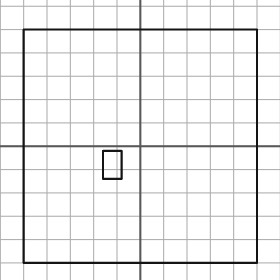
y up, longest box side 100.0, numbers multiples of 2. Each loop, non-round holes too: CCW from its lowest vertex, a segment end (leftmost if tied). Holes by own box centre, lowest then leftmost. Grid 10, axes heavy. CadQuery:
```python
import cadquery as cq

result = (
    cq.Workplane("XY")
    .moveTo(-50.0, -50.0)
    .lineTo(50.0, -50.0)
    .lineTo(50.0, 50.0)
    .lineTo(-50.0, 50.0)
    .close()
    .moveTo(-16.0, -14.0)
    .lineTo(-8.0, -14.0)
    .lineTo(-8.0, -2.0)
    .lineTo(-16.0, -2.0)
    .close()
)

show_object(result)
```